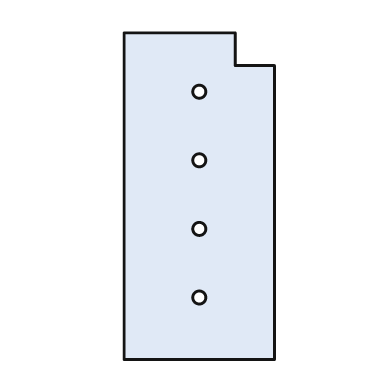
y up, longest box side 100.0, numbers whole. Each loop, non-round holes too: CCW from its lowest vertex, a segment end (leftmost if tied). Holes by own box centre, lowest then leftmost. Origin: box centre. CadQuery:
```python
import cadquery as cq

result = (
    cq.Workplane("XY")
    .moveTo(-23.0, -50.0)
    .lineTo(23.0, -50.0)
    .lineTo(23.0, 40.0)
    .lineTo(11.0, 40.0)
    .lineTo(11.0, 50.0)
    .lineTo(-23.0, 50.0)
    .close()
    .moveTo(0.0, -31.0)
    .circle(2.0)
    .moveTo(0.0, -10.0)
    .circle(2.0)
    .moveTo(0.0, 11.0)
    .circle(2.0)
    .moveTo(0.0, 32.0)
    .circle(2.0)
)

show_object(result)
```